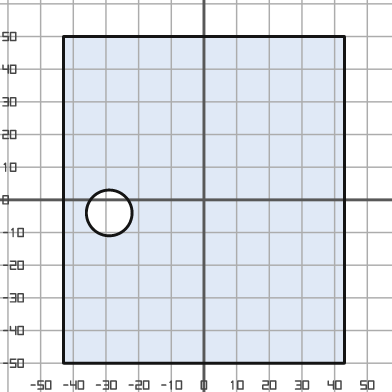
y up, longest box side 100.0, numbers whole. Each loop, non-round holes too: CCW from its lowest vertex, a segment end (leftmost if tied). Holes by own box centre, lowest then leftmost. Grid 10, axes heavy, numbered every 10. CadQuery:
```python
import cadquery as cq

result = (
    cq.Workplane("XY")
    .moveTo(-43.0, -50.0)
    .lineTo(43.0, -50.0)
    .lineTo(43.0, 50.0)
    .lineTo(-43.0, 50.0)
    .close()
    .moveTo(-29.0, -4.0)
    .circle(7.0)
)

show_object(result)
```